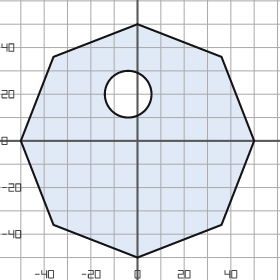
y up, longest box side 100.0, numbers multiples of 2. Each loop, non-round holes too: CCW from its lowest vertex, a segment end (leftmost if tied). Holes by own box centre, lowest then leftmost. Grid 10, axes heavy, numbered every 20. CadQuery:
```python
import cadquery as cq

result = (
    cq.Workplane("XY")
    .moveTo(0.0, -50.0)
    .lineTo(36.0, -36.0)
    .lineTo(50.0, 0.0)
    .lineTo(36.0, 36.0)
    .lineTo(0.0, 50.0)
    .lineTo(-36.0, 36.0)
    .lineTo(-50.0, 0.0)
    .lineTo(-36.0, -36.0)
    .close()
    .moveTo(-4.0, 20.0)
    .circle(10.0)
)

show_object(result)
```